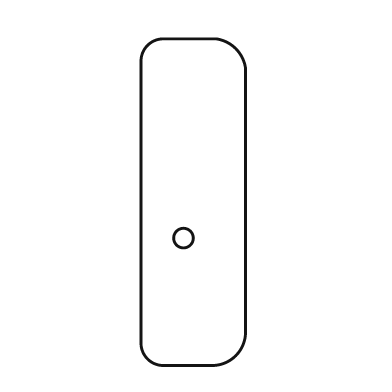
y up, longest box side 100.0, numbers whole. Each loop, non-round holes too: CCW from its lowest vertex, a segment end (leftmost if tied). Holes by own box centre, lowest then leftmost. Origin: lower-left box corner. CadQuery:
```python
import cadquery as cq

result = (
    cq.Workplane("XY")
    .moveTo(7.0, 0.0)
    .lineTo(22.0, 0.0)
    .threePointArc((29.0, 3.0), (32.0, 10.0))
    .lineTo(32.0, 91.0)
    .threePointArc((29.0, 97.0), (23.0, 100.0))
    .lineTo(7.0, 100.0)
    .threePointArc((2.0, 98.0), (0.0, 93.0))
    .lineTo(0.0, 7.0)
    .threePointArc((2.0, 2.0), (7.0, 0.0))
    .close()
    .moveTo(13.0, 39.0)
    .circle(3.0)
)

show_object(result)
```